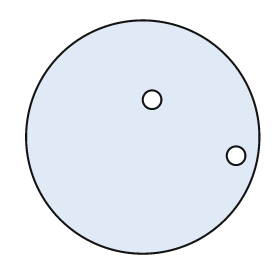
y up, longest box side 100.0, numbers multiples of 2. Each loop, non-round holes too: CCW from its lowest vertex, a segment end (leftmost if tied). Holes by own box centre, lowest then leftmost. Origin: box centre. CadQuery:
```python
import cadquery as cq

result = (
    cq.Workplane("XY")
    .moveTo(0.0, 0.0)
    .circle(50.0)
    .moveTo(40.0, -8.0)
    .circle(4.0)
    .moveTo(4.0, 16.0)
    .circle(4.0)
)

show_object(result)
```